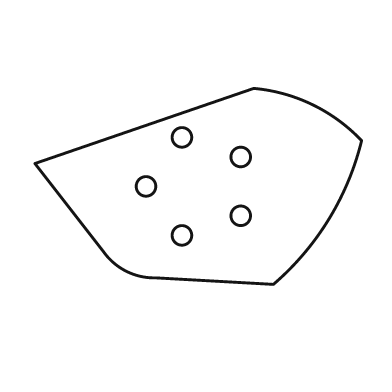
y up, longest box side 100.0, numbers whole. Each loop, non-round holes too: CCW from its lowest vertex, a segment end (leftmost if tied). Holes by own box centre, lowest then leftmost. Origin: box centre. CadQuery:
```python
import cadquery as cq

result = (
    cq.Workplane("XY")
    .moveTo(23.0, -30.0)
    .threePointArc((40.0, -10.0), (50.0, 14.0))
    .threePointArc((35.0, 25.0), (17.0, 30.0))
    .lineTo(-50.0, 7.0)
    .lineTo(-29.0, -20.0)
    .threePointArc((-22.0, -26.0), (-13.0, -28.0))
    .close()
    .moveTo(-5.0, -15.0)
    .circle(3.0)
    .moveTo(13.0, -9.0)
    .circle(3.0)
    .moveTo(-16.0, 0.0)
    .circle(3.0)
    .moveTo(13.0, 9.0)
    .circle(3.0)
    .moveTo(-5.0, 15.0)
    .circle(3.0)
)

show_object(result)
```